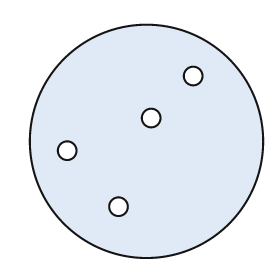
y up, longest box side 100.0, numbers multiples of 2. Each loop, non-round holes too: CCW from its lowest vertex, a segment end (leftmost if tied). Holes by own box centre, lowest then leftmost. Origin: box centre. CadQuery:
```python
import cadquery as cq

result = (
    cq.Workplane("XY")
    .moveTo(0.0, 0.0)
    .circle(50.0)
    .moveTo(-12.0, -28.0)
    .circle(4.0)
    .moveTo(-34.0, -4.0)
    .circle(4.0)
    .moveTo(2.0, 10.0)
    .circle(4.0)
    .moveTo(20.0, 28.0)
    .circle(4.0)
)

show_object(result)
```